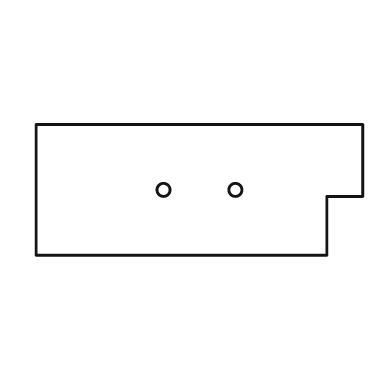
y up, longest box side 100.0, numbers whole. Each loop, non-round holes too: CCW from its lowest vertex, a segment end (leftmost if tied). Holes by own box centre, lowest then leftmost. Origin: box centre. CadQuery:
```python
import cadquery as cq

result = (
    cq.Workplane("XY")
    .moveTo(-50.0, -20.0)
    .lineTo(39.0, -20.0)
    .lineTo(39.0, -2.0)
    .lineTo(50.0, -2.0)
    .lineTo(50.0, 20.0)
    .lineTo(-50.0, 20.0)
    .close()
    .moveTo(-11.0, 0.0)
    .circle(2.0)
    .moveTo(11.0, 0.0)
    .circle(2.0)
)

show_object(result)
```